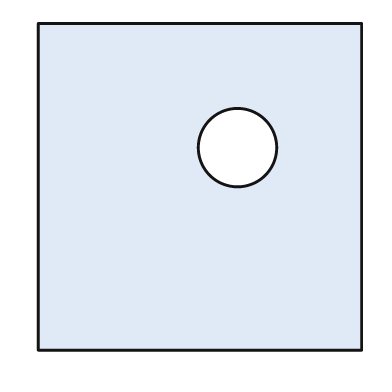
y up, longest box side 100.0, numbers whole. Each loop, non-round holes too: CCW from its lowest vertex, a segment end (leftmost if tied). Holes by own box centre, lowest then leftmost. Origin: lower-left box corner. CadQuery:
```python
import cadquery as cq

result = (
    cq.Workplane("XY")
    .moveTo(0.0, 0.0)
    .lineTo(99.0, 0.0)
    .lineTo(99.0, 100.0)
    .lineTo(0.0, 100.0)
    .close()
    .moveTo(61.0, 62.0)
    .circle(12.0)
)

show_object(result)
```